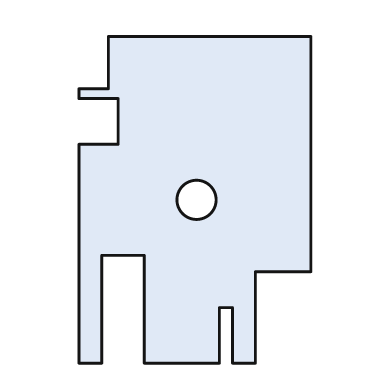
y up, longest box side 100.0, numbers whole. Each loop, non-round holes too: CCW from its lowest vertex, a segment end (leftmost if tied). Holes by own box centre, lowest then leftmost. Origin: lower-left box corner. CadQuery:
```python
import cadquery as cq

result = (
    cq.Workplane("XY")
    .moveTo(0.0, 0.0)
    .lineTo(7.0, 0.0)
    .lineTo(7.0, 33.0)
    .lineTo(20.0, 33.0)
    .lineTo(20.0, 0.0)
    .lineTo(43.0, 0.0)
    .lineTo(43.0, 17.0)
    .lineTo(47.0, 17.0)
    .lineTo(47.0, 0.0)
    .lineTo(54.0, 0.0)
    .lineTo(54.0, 28.0)
    .lineTo(71.0, 28.0)
    .lineTo(71.0, 100.0)
    .lineTo(9.0, 100.0)
    .lineTo(9.0, 84.0)
    .lineTo(0.0, 84.0)
    .lineTo(0.0, 81.0)
    .lineTo(12.0, 81.0)
    .lineTo(12.0, 67.0)
    .lineTo(0.0, 67.0)
    .close()
    .moveTo(36.0, 50.0)
    .circle(6.0)
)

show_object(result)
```